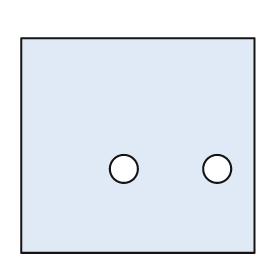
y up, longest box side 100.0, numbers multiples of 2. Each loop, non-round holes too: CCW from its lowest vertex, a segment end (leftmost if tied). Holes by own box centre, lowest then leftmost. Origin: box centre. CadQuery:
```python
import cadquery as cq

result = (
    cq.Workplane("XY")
    .moveTo(-50.0, -46.0)
    .lineTo(50.0, -46.0)
    .lineTo(50.0, 46.0)
    .lineTo(-50.0, 46.0)
    .close()
    .moveTo(-6.0, -10.0)
    .circle(6.0)
    .moveTo(34.0, -10.0)
    .circle(6.0)
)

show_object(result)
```